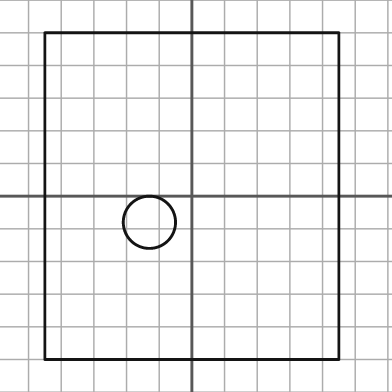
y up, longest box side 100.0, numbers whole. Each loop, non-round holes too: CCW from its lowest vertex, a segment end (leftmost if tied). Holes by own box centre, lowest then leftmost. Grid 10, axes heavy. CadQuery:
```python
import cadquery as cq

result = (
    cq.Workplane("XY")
    .moveTo(-45.0, -50.0)
    .lineTo(45.0, -50.0)
    .lineTo(45.0, 50.0)
    .lineTo(-45.0, 50.0)
    .close()
    .moveTo(-13.0, -8.0)
    .circle(8.0)
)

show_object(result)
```